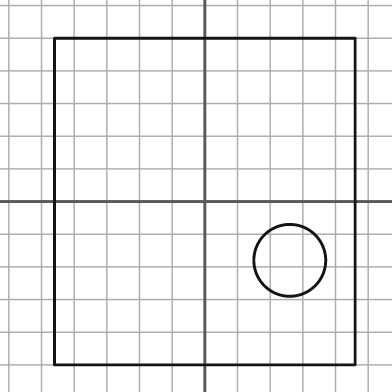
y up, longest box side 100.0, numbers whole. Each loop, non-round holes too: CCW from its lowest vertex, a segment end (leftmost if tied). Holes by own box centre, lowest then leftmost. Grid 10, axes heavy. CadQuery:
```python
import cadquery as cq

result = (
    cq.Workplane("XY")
    .moveTo(-46.0, -50.0)
    .lineTo(46.0, -50.0)
    .lineTo(46.0, 50.0)
    .lineTo(-46.0, 50.0)
    .close()
    .moveTo(26.0, -18.0)
    .circle(11.0)
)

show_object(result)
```